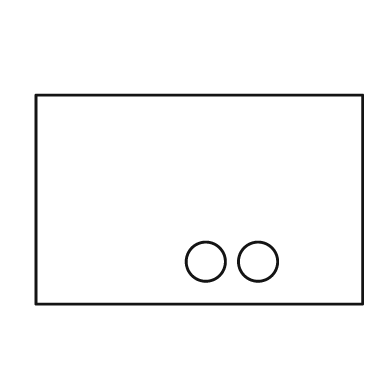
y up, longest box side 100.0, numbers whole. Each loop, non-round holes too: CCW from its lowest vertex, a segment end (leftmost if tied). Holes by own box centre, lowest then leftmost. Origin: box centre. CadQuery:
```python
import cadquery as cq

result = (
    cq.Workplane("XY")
    .moveTo(-50.0, -32.0)
    .lineTo(50.0, -32.0)
    .lineTo(50.0, 32.0)
    .lineTo(-50.0, 32.0)
    .close()
    .moveTo(2.0, -19.0)
    .circle(6.0)
    .moveTo(18.0, -19.0)
    .circle(6.0)
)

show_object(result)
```